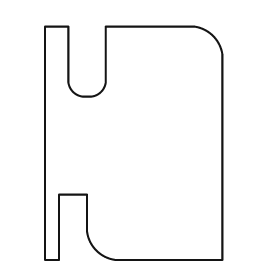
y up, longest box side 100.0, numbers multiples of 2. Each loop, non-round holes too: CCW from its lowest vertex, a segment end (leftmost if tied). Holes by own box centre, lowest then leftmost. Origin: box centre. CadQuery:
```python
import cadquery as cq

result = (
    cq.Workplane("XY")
    .moveTo(-38.0, -50.0)
    .lineTo(-32.0, -50.0)
    .lineTo(-32.0, -22.0)
    .lineTo(-20.0, -22.0)
    .lineTo(-20.0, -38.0)
    .threePointArc((-16.0, -46.0), (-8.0, -50.0))
    .lineTo(38.0, -50.0)
    .lineTo(38.0, 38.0)
    .threePointArc((34.0, 46.0), (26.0, 50.0))
    .lineTo(-12.0, 50.0)
    .lineTo(-12.0, 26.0)
    .threePointArc((-14.0, 22.0), (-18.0, 20.0))
    .lineTo(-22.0, 20.0)
    .threePointArc((-26.0, 22.0), (-28.0, 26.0))
    .lineTo(-28.0, 50.0)
    .lineTo(-38.0, 50.0)
    .close()
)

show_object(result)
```